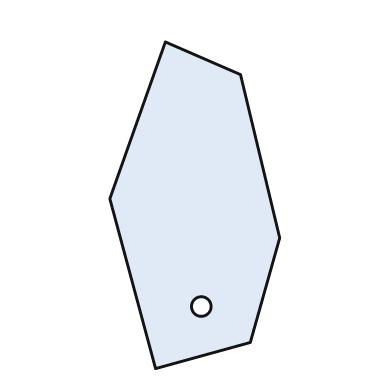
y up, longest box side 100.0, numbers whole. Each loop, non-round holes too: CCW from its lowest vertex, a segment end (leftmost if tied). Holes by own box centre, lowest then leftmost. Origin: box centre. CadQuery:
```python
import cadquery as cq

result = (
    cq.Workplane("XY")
    .moveTo(-12.0, -50.0)
    .lineTo(17.0, -42.0)
    .lineTo(26.0, -10.0)
    .lineTo(14.0, 40.0)
    .lineTo(-9.0, 50.0)
    .lineTo(-26.0, 2.0)
    .close()
    .moveTo(2.0, -31.0)
    .circle(3.0)
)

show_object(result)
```